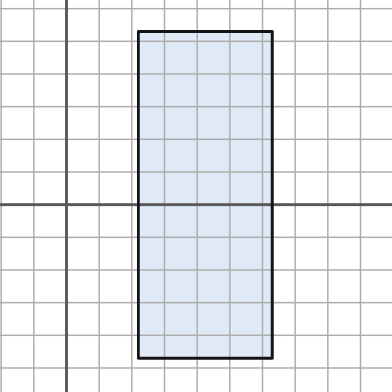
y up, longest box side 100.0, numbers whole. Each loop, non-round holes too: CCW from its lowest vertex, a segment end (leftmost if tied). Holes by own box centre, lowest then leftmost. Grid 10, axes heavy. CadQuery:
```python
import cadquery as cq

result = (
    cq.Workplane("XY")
    .moveTo(22.0, -47.0)
    .lineTo(63.0, -47.0)
    .lineTo(63.0, 53.0)
    .lineTo(22.0, 53.0)
    .close()
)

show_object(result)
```